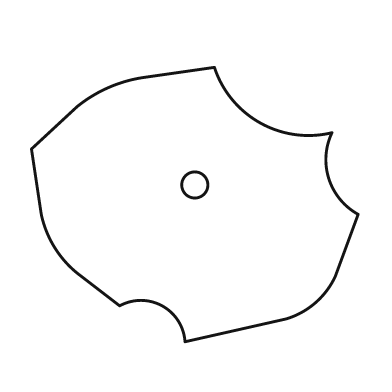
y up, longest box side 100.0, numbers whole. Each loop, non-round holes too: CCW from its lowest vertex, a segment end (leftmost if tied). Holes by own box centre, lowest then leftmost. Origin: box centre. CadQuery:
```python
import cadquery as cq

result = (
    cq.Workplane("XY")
    .moveTo(-3.0, -42.0)
    .lineTo(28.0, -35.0)
    .threePointArc((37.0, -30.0), (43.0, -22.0))
    .lineTo(50.0, -3.0)
    .threePointArc((41.0, 8.0), (42.0, 22.0))
    .threePointArc((20.0, 25.0), (6.0, 42.0))
    .lineTo(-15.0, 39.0)
    .threePointArc((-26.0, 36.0), (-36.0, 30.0))
    .lineTo(-50.0, 17.0)
    .lineTo(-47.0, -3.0)
    .threePointArc((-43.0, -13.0), (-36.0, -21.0))
    .lineTo(-23.0, -31.0)
    .threePointArc((-10.0, -31.0), (-3.0, -42.0))
    .close()
    .moveTo(0.0, 6.0)
    .circle(4.0)
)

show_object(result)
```